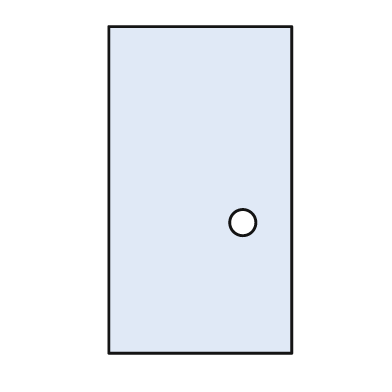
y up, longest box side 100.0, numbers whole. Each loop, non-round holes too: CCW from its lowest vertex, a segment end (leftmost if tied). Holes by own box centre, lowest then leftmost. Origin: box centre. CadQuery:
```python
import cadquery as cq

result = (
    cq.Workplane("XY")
    .moveTo(-28.0, -50.0)
    .lineTo(28.0, -50.0)
    .lineTo(28.0, 50.0)
    .lineTo(-28.0, 50.0)
    .close()
    .moveTo(13.0, -10.0)
    .circle(4.0)
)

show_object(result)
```